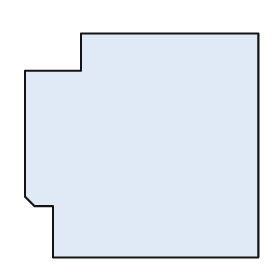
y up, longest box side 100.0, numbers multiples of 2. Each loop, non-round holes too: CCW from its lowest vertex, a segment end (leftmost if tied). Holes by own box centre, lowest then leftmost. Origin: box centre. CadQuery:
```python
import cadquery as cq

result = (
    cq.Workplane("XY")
    .moveTo(-38.0, -48.0)
    .lineTo(50.0, -48.0)
    .lineTo(50.0, 48.0)
    .lineTo(-26.0, 48.0)
    .lineTo(-26.0, 32.0)
    .lineTo(-50.0, 32.0)
    .lineTo(-50.0, -22.0)
    .lineTo(-46.0, -26.0)
    .lineTo(-38.0, -26.0)
    .close()
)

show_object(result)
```